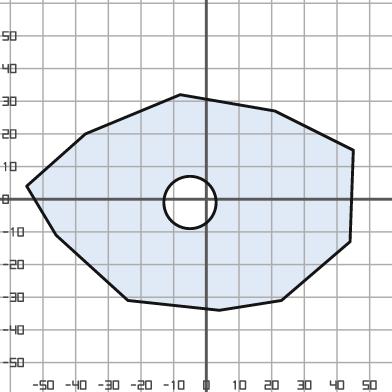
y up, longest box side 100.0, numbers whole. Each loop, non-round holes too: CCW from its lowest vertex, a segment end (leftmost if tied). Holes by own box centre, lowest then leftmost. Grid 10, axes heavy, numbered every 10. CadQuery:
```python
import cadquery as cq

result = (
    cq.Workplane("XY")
    .moveTo(4.0, -34.0)
    .lineTo(23.0, -31.0)
    .lineTo(44.0, -13.0)
    .lineTo(45.0, 15.0)
    .lineTo(21.0, 27.0)
    .lineTo(-8.0, 32.0)
    .lineTo(-37.0, 20.0)
    .lineTo(-55.0, 4.0)
    .lineTo(-46.0, -11.0)
    .lineTo(-24.0, -31.0)
    .close()
    .moveTo(-5.0, -1.0)
    .circle(8.0)
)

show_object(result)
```